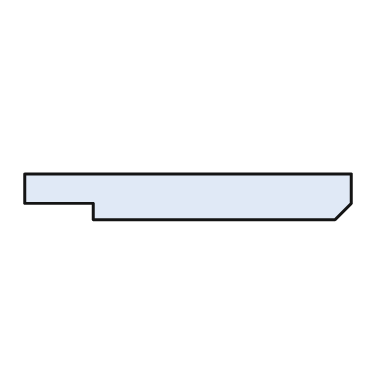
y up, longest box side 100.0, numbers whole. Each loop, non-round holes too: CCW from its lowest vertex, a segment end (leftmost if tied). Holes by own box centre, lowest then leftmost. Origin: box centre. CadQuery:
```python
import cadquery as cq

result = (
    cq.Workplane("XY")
    .moveTo(-29.0, -7.0)
    .lineTo(45.0, -7.0)
    .lineTo(50.0, -2.0)
    .lineTo(50.0, 7.0)
    .lineTo(-50.0, 7.0)
    .lineTo(-50.0, -2.0)
    .lineTo(-29.0, -2.0)
    .close()
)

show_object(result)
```